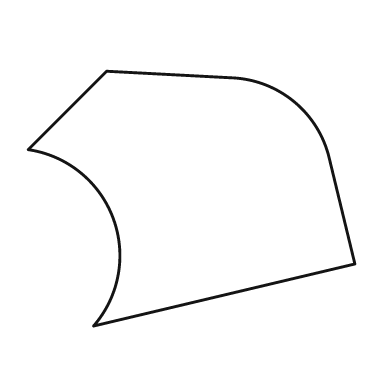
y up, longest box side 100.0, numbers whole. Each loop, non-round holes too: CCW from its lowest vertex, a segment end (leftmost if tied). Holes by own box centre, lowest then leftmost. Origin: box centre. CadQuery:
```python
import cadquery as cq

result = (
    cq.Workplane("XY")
    .moveTo(-30.0, -39.0)
    .lineTo(50.0, -20.0)
    .lineTo(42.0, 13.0)
    .threePointArc((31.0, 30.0), (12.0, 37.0))
    .lineTo(-26.0, 39.0)
    .lineTo(-50.0, 15.0)
    .threePointArc((-24.0, -6.0), (-30.0, -39.0))
    .close()
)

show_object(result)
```